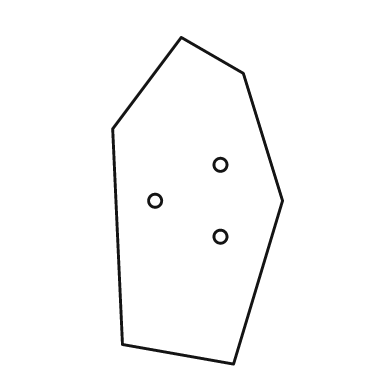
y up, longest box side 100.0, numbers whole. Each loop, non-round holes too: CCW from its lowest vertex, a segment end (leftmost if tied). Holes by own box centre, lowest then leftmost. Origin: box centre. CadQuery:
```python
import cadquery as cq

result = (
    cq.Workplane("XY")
    .moveTo(11.0, -50.0)
    .lineTo(26.0, 0.0)
    .lineTo(14.0, 39.0)
    .lineTo(-5.0, 50.0)
    .lineTo(-26.0, 22.0)
    .lineTo(-23.0, -44.0)
    .close()
    .moveTo(7.0, -11.0)
    .circle(2.0)
    .moveTo(-13.0, 0.0)
    .circle(2.0)
    .moveTo(7.0, 11.0)
    .circle(2.0)
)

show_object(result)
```